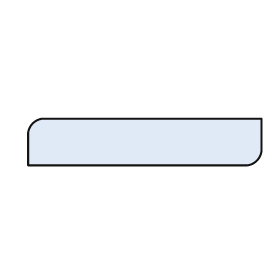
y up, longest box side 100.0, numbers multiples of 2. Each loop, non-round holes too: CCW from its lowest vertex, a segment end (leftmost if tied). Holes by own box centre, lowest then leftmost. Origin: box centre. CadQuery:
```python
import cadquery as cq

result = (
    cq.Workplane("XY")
    .moveTo(-50.0, -10.0)
    .lineTo(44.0, -10.0)
    .threePointArc((48.0, -8.0), (50.0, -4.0))
    .lineTo(50.0, 10.0)
    .lineTo(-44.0, 10.0)
    .threePointArc((-48.0, 8.0), (-50.0, 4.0))
    .close()
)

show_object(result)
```